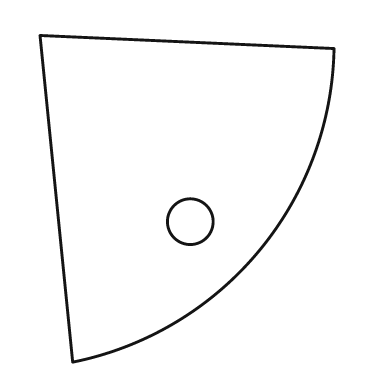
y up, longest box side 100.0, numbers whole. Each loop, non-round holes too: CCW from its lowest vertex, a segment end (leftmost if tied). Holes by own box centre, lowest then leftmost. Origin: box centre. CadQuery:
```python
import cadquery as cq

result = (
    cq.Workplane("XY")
    .moveTo(-35.0, -50.0)
    .threePointArc((22.0, -16.0), (45.0, 46.0))
    .lineTo(-45.0, 50.0)
    .close()
    .moveTo(1.0, -7.0)
    .circle(7.0)
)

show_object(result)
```